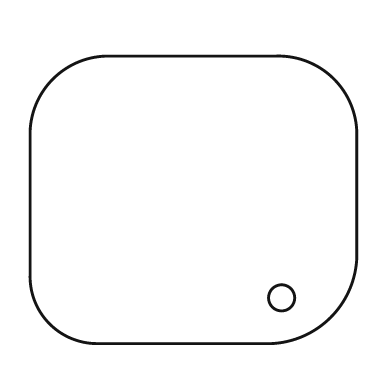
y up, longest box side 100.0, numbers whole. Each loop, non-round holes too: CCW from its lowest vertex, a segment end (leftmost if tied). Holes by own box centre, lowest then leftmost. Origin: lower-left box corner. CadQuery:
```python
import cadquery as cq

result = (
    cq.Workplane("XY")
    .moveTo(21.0, 0.0)
    .lineTo(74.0, 0.0)
    .threePointArc((92.0, 8.0), (100.0, 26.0))
    .lineTo(100.0, 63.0)
    .threePointArc((93.0, 81.0), (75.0, 88.0))
    .lineTo(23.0, 88.0)
    .threePointArc((7.0, 81.0), (0.0, 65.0))
    .lineTo(0.0, 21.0)
    .threePointArc((6.0, 6.0), (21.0, 0.0))
    .close()
    .moveTo(77.0, 14.0)
    .circle(4.0)
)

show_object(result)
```